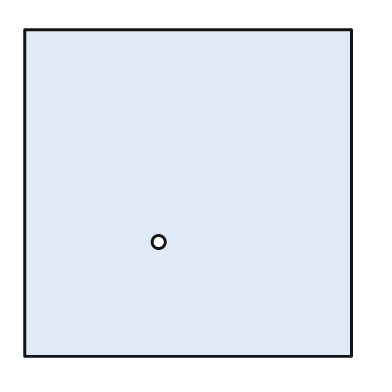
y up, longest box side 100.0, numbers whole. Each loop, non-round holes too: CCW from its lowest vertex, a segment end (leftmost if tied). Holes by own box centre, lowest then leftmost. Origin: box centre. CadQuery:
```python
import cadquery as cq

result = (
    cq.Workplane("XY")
    .moveTo(-50.0, -50.0)
    .lineTo(50.0, -50.0)
    .lineTo(50.0, 50.0)
    .lineTo(-50.0, 50.0)
    .close()
    .moveTo(-9.0, -15.0)
    .circle(2.0)
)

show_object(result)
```